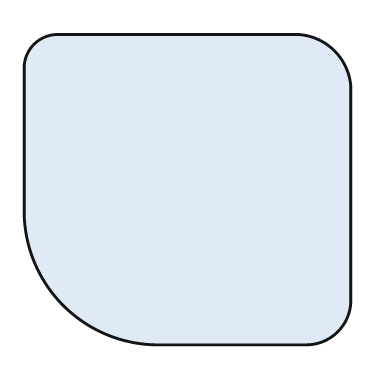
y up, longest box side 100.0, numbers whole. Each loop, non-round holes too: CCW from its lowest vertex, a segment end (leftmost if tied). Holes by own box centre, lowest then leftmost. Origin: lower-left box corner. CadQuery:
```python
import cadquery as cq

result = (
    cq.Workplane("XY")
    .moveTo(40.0, 0.0)
    .lineTo(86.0, 0.0)
    .threePointArc((96.0, 4.0), (100.0, 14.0))
    .lineTo(100.0, 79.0)
    .threePointArc((95.0, 90.0), (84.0, 95.0))
    .lineTo(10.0, 95.0)
    .threePointArc((3.0, 92.0), (0.0, 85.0))
    .lineTo(0.0, 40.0)
    .threePointArc((12.0, 12.0), (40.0, 0.0))
    .close()
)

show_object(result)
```